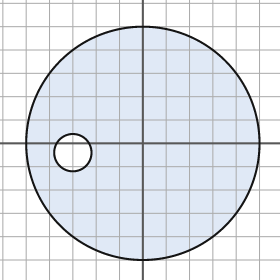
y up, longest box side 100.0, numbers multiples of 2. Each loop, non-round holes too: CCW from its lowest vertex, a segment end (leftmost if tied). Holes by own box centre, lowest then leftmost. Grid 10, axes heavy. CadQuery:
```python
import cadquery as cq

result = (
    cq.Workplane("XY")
    .moveTo(0.0, 0.0)
    .circle(50.0)
    .moveTo(-30.0, -4.0)
    .circle(8.0)
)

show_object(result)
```